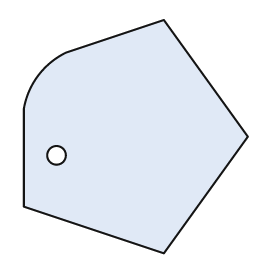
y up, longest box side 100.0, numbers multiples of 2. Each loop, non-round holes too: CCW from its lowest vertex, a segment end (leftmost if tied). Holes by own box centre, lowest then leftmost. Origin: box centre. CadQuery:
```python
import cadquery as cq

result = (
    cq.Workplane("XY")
    .moveTo(12.0, -50.0)
    .lineTo(48.0, 0.0)
    .lineTo(12.0, 50.0)
    .lineTo(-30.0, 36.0)
    .threePointArc((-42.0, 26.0), (-48.0, 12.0))
    .lineTo(-48.0, -30.0)
    .close()
    .moveTo(-34.0, -8.0)
    .circle(4.0)
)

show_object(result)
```